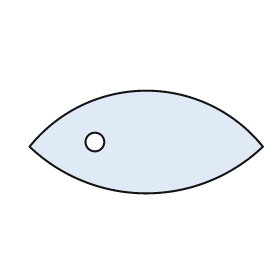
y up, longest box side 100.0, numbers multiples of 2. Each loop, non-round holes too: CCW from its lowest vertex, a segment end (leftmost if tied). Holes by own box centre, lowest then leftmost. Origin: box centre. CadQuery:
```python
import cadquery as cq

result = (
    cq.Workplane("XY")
    .moveTo(-50.0, -2.0)
    .threePointArc((0.0, -22.0), (50.0, -2.0))
    .threePointArc((0.0, 22.0), (-50.0, -2.0))
    .close()
    .moveTo(-22.0, 0.0)
    .circle(4.0)
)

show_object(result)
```